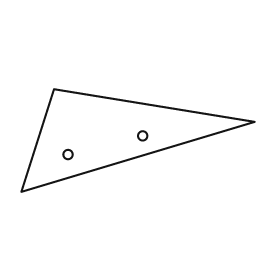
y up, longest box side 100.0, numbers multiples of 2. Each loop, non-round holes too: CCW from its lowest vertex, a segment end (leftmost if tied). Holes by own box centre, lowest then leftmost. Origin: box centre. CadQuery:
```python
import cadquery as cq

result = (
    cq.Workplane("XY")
    .moveTo(-50.0, -22.0)
    .lineTo(50.0, 8.0)
    .lineTo(-36.0, 22.0)
    .close()
    .moveTo(-30.0, -6.0)
    .circle(2.0)
    .moveTo(2.0, 2.0)
    .circle(2.0)
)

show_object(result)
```